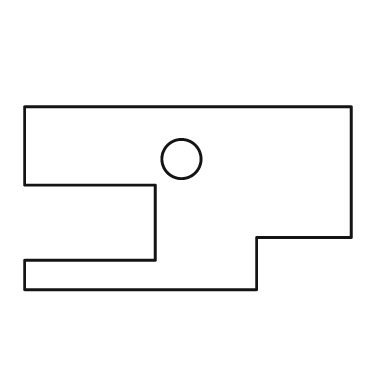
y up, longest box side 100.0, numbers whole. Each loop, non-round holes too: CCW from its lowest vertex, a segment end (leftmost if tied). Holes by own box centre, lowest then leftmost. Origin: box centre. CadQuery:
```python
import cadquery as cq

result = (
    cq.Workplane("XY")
    .moveTo(-50.0, -28.0)
    .lineTo(21.0, -28.0)
    .lineTo(21.0, -12.0)
    .lineTo(50.0, -12.0)
    .lineTo(50.0, 28.0)
    .lineTo(-50.0, 28.0)
    .lineTo(-50.0, 4.0)
    .lineTo(-10.0, 4.0)
    .lineTo(-10.0, -19.0)
    .lineTo(-50.0, -19.0)
    .close()
    .moveTo(-2.0, 12.0)
    .circle(6.0)
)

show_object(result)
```